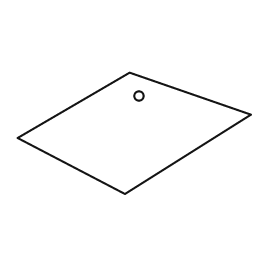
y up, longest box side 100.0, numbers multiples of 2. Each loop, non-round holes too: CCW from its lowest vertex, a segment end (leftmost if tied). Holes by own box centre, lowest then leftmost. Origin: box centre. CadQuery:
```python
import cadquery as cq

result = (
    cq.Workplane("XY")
    .moveTo(-4.0, -26.0)
    .lineTo(50.0, 8.0)
    .lineTo(-2.0, 26.0)
    .lineTo(-50.0, -2.0)
    .close()
    .moveTo(2.0, 16.0)
    .circle(2.0)
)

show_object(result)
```